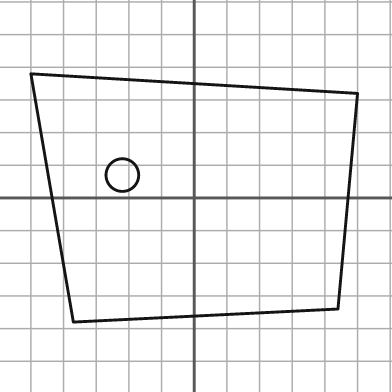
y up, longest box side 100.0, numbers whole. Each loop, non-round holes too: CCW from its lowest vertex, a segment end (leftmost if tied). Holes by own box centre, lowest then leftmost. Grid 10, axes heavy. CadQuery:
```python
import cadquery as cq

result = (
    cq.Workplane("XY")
    .moveTo(-37.0, -38.0)
    .lineTo(44.0, -34.0)
    .lineTo(50.0, 32.0)
    .lineTo(-50.0, 38.0)
    .close()
    .moveTo(-22.0, 7.0)
    .circle(5.0)
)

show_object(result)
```